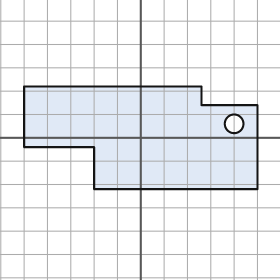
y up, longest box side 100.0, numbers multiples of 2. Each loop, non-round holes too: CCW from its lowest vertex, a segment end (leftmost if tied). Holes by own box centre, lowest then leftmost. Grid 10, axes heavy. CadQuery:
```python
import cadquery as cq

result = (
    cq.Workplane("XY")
    .moveTo(-20.0, -22.0)
    .lineTo(50.0, -22.0)
    .lineTo(50.0, 14.0)
    .lineTo(26.0, 14.0)
    .lineTo(26.0, 22.0)
    .lineTo(-50.0, 22.0)
    .lineTo(-50.0, -4.0)
    .lineTo(-20.0, -4.0)
    .close()
    .moveTo(40.0, 6.0)
    .circle(4.0)
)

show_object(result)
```